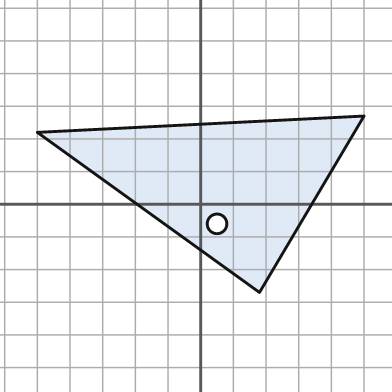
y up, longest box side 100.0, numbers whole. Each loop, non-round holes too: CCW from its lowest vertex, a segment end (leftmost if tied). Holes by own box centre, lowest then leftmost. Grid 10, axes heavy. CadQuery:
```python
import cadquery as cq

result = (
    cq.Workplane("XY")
    .moveTo(18.0, -27.0)
    .lineTo(50.0, 27.0)
    .lineTo(-50.0, 22.0)
    .close()
    .moveTo(5.0, -6.0)
    .circle(3.0)
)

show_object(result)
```